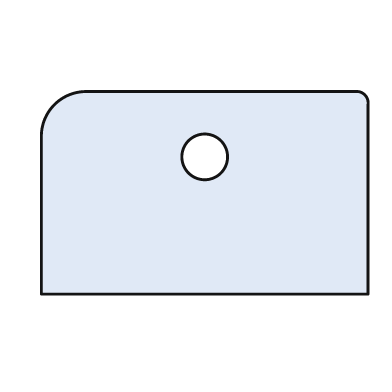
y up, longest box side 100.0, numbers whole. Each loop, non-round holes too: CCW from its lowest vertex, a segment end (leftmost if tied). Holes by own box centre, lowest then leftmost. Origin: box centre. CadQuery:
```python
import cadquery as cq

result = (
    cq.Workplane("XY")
    .moveTo(-50.0, -31.0)
    .lineTo(50.0, -31.0)
    .lineTo(50.0, 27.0)
    .threePointArc((49.0, 30.0), (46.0, 31.0))
    .lineTo(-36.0, 31.0)
    .threePointArc((-46.0, 27.0), (-50.0, 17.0))
    .close()
    .moveTo(0.0, 11.0)
    .circle(7.0)
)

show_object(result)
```